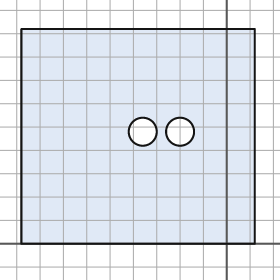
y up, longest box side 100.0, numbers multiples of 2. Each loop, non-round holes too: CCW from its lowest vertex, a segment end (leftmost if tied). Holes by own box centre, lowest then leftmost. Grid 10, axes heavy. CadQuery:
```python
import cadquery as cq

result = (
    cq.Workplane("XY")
    .moveTo(-88.0, 0.0)
    .lineTo(12.0, 0.0)
    .lineTo(12.0, 92.0)
    .lineTo(-88.0, 92.0)
    .close()
    .moveTo(-36.0, 48.0)
    .circle(6.0)
    .moveTo(-20.0, 48.0)
    .circle(6.0)
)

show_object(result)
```